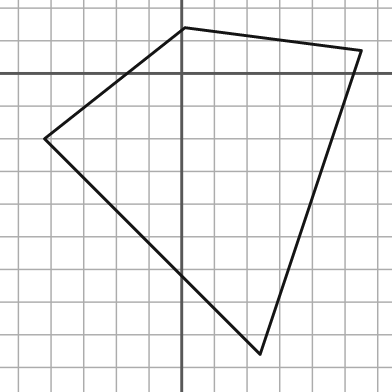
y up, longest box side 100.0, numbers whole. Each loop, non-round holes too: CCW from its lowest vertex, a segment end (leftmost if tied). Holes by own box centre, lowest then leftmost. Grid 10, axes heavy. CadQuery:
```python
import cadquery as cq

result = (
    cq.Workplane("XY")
    .moveTo(24.0, -86.0)
    .lineTo(55.0, 7.0)
    .lineTo(1.0, 14.0)
    .lineTo(-42.0, -20.0)
    .close()
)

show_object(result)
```